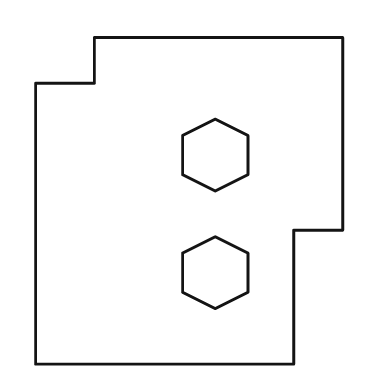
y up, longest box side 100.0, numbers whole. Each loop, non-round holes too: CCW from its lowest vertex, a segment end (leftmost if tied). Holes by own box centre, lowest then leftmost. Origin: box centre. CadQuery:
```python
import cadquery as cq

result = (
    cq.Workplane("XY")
    .moveTo(-47.0, -50.0)
    .lineTo(32.0, -50.0)
    .lineTo(32.0, -9.0)
    .lineTo(47.0, -9.0)
    .lineTo(47.0, 50.0)
    .lineTo(-29.0, 50.0)
    .lineTo(-29.0, 36.0)
    .lineTo(-47.0, 36.0)
    .close()
    .moveTo(8.0, -33.0)
    .lineTo(18.0, -28.0)
    .lineTo(18.0, -16.0)
    .lineTo(8.0, -11.0)
    .lineTo(-2.0, -16.0)
    .lineTo(-2.0, -28.0)
    .close()
    .moveTo(8.0, 3.0)
    .lineTo(18.0, 8.0)
    .lineTo(18.0, 20.0)
    .lineTo(8.0, 25.0)
    .lineTo(-2.0, 20.0)
    .lineTo(-2.0, 8.0)
    .close()
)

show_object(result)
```